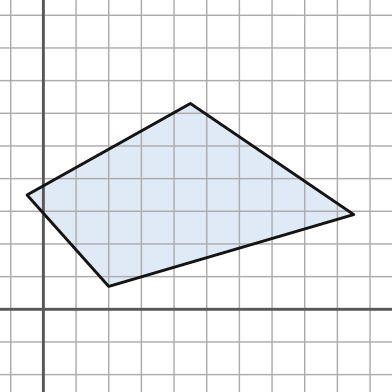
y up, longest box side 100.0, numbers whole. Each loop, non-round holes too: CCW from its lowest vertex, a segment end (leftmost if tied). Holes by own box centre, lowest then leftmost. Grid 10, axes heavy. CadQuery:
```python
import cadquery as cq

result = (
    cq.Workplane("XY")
    .moveTo(20.0, 7.0)
    .lineTo(95.0, 29.0)
    .lineTo(45.0, 63.0)
    .lineTo(-5.0, 35.0)
    .close()
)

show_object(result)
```